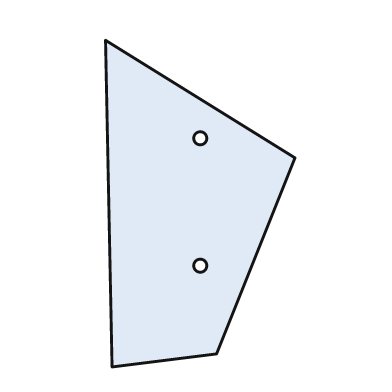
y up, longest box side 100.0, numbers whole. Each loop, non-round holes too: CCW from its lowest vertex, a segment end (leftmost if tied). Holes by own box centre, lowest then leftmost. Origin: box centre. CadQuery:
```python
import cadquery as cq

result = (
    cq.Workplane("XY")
    .moveTo(-27.0, -50.0)
    .lineTo(5.0, -46.0)
    .lineTo(29.0, 14.0)
    .lineTo(-29.0, 50.0)
    .close()
    .moveTo(0.0, -19.0)
    .circle(2.0)
    .moveTo(0.0, 20.0)
    .circle(2.0)
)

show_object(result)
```